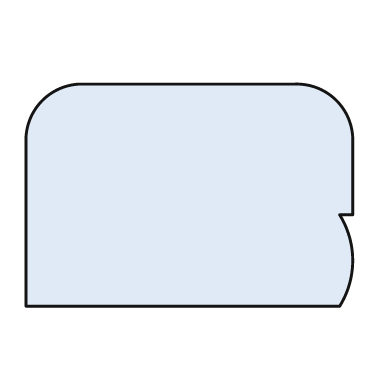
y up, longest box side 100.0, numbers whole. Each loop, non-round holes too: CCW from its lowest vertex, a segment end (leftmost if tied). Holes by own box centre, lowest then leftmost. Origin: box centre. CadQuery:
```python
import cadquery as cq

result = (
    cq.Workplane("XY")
    .moveTo(-50.0, -34.0)
    .lineTo(46.0, -34.0)
    .threePointArc((50.0, -20.0), (46.0, -6.0))
    .lineTo(50.0, -6.0)
    .lineTo(50.0, 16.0)
    .threePointArc((45.0, 29.0), (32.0, 34.0))
    .lineTo(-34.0, 34.0)
    .threePointArc((-45.0, 29.0), (-50.0, 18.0))
    .close()
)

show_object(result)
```